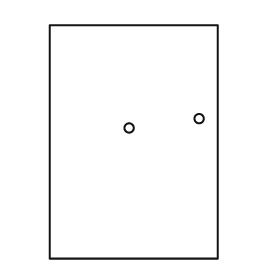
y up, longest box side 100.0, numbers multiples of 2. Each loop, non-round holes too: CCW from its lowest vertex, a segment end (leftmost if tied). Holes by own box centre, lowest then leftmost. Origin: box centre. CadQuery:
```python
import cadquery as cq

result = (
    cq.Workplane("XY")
    .moveTo(-36.0, -50.0)
    .lineTo(36.0, -50.0)
    .lineTo(36.0, 50.0)
    .lineTo(-36.0, 50.0)
    .close()
    .moveTo(-2.0, 6.0)
    .circle(2.0)
    .moveTo(28.0, 10.0)
    .circle(2.0)
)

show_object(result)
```